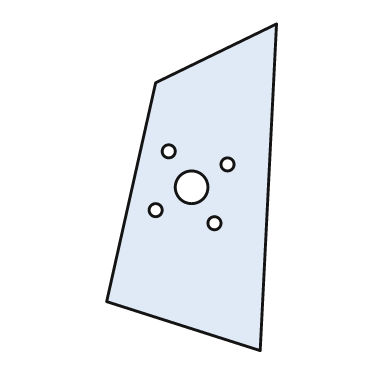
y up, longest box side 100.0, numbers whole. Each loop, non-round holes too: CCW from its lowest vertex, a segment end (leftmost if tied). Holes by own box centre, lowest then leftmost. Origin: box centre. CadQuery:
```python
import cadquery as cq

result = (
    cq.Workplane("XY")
    .moveTo(21.0, -50.0)
    .lineTo(26.0, 50.0)
    .lineTo(-11.0, 32.0)
    .lineTo(-26.0, -35.0)
    .close()
    .moveTo(7.0, -11.0)
    .circle(2.0)
    .moveTo(-11.0, -7.0)
    .circle(2.0)
    .moveTo(0.0, 0.0)
    .circle(5.0)
    .moveTo(11.0, 7.0)
    .circle(2.0)
    .moveTo(-7.0, 11.0)
    .circle(2.0)
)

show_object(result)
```